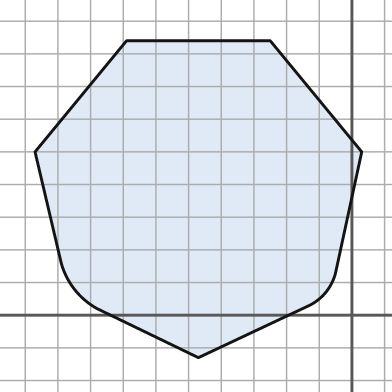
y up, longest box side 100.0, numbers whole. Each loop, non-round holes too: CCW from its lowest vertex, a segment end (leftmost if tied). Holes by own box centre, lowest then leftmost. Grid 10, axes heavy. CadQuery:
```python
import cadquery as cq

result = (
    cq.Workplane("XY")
    .moveTo(-47.0, -13.0)
    .lineTo(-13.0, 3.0)
    .threePointArc((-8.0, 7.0), (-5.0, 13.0))
    .lineTo(3.0, 50.0)
    .lineTo(-25.0, 84.0)
    .lineTo(-69.0, 84.0)
    .lineTo(-97.0, 50.0)
    .lineTo(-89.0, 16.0)
    .threePointArc((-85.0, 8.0), (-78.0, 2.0))
    .close()
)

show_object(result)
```